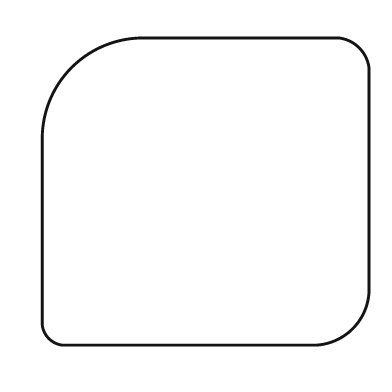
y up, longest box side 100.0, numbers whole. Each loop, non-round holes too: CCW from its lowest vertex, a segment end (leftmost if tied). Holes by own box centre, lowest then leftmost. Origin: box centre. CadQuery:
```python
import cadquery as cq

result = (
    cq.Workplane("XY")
    .moveTo(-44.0, -47.0)
    .lineTo(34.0, -47.0)
    .threePointArc((45.0, -42.0), (50.0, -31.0))
    .lineTo(50.0, 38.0)
    .threePointArc((47.0, 44.0), (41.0, 47.0))
    .lineTo(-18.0, 47.0)
    .threePointArc((-41.0, 38.0), (-50.0, 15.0))
    .lineTo(-50.0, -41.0)
    .threePointArc((-48.0, -45.0), (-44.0, -47.0))
    .close()
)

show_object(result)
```